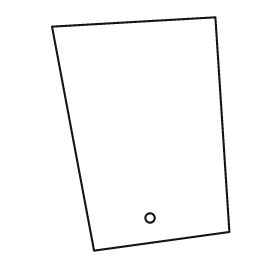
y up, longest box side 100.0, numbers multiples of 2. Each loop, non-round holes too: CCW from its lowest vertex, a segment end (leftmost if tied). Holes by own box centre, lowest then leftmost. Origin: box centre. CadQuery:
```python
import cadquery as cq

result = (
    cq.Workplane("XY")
    .moveTo(-20.0, -50.0)
    .lineTo(38.0, -42.0)
    .lineTo(32.0, 50.0)
    .lineTo(-38.0, 46.0)
    .close()
    .moveTo(4.0, -36.0)
    .circle(2.0)
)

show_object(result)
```